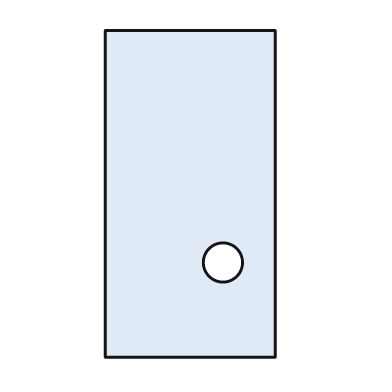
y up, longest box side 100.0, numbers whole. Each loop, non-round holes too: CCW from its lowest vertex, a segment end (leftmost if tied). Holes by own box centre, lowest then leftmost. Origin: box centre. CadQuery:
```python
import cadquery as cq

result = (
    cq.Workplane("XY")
    .moveTo(-26.0, -50.0)
    .lineTo(26.0, -50.0)
    .lineTo(26.0, 50.0)
    .lineTo(-26.0, 50.0)
    .close()
    .moveTo(10.0, -21.0)
    .circle(6.0)
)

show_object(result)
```